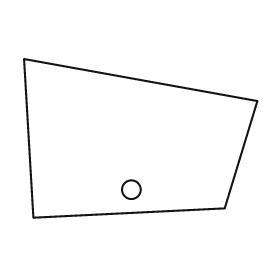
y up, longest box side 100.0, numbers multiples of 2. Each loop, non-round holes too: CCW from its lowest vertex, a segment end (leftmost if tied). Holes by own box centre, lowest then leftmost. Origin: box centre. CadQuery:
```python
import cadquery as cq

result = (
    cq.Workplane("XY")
    .moveTo(-46.0, -34.0)
    .lineTo(36.0, -30.0)
    .lineTo(50.0, 16.0)
    .lineTo(-50.0, 34.0)
    .close()
    .moveTo(-4.0, -22.0)
    .circle(4.0)
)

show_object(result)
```